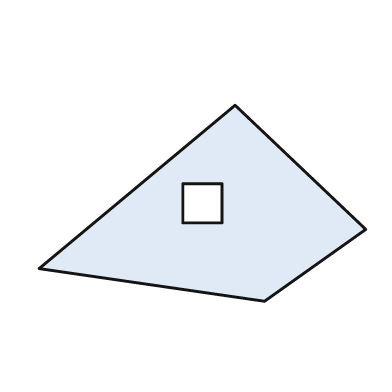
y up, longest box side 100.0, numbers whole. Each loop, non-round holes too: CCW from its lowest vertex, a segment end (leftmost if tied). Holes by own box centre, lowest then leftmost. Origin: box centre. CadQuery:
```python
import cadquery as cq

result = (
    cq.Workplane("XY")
    .moveTo(19.0, -30.0)
    .lineTo(50.0, -8.0)
    .lineTo(10.0, 30.0)
    .lineTo(-50.0, -20.0)
    .close()
    .moveTo(-6.0, -6.0)
    .lineTo(6.0, -6.0)
    .lineTo(6.0, 6.0)
    .lineTo(-6.0, 6.0)
    .close()
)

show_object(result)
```